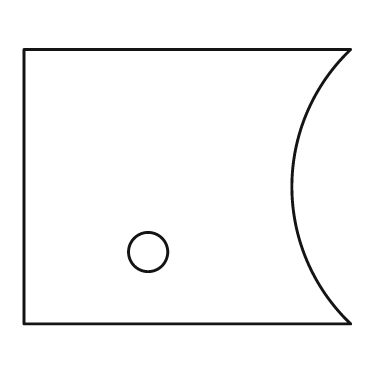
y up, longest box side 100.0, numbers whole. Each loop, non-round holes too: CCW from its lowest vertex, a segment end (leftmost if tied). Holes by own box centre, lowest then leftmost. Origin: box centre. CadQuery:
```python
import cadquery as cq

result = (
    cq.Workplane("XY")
    .moveTo(-50.0, -42.0)
    .lineTo(50.0, -42.0)
    .threePointArc((32.0, 0.0), (50.0, 42.0))
    .lineTo(-50.0, 42.0)
    .close()
    .moveTo(-12.0, -20.0)
    .circle(6.0)
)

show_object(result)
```